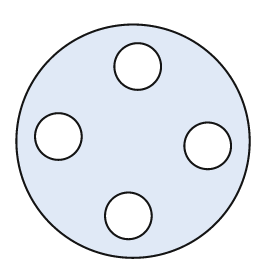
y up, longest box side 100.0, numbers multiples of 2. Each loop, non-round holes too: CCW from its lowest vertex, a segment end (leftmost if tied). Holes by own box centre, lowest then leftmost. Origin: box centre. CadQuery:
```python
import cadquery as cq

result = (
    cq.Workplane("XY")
    .moveTo(0.0, 0.0)
    .circle(50.0)
    .moveTo(-2.0, -32.0)
    .circle(10.0)
    .moveTo(32.0, -2.0)
    .circle(10.0)
    .moveTo(-32.0, 2.0)
    .circle(10.0)
    .moveTo(2.0, 32.0)
    .circle(10.0)
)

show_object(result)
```